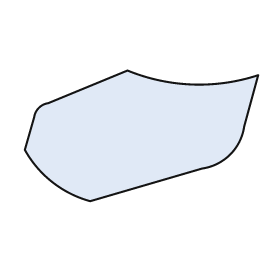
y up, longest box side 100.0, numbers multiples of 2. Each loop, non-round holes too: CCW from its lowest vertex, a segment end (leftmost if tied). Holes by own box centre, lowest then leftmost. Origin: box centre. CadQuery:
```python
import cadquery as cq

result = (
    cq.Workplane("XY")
    .moveTo(-22.0, -28.0)
    .lineTo(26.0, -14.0)
    .threePointArc((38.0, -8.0), (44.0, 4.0))
    .lineTo(50.0, 26.0)
    .threePointArc((22.0, 22.0), (-6.0, 28.0))
    .lineTo(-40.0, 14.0)
    .threePointArc((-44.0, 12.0), (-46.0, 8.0))
    .lineTo(-50.0, -6.0)
    .threePointArc((-38.0, -20.0), (-22.0, -28.0))
    .close()
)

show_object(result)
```